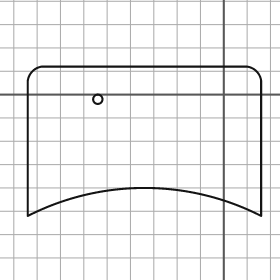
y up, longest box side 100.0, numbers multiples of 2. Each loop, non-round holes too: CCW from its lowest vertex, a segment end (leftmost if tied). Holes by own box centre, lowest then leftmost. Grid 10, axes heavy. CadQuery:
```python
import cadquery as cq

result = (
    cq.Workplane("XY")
    .moveTo(-84.0, -52.0)
    .threePointArc((-34.0, -40.0), (16.0, -52.0))
    .lineTo(16.0, 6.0)
    .threePointArc((14.0, 10.0), (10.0, 12.0))
    .lineTo(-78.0, 12.0)
    .threePointArc((-82.0, 10.0), (-84.0, 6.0))
    .close()
    .moveTo(-54.0, -2.0)
    .circle(2.0)
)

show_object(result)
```